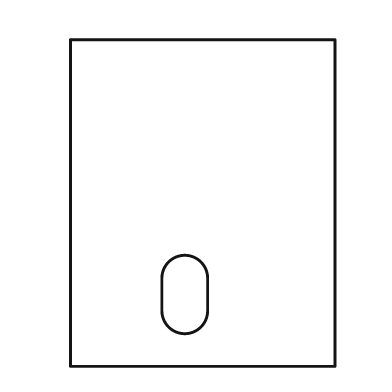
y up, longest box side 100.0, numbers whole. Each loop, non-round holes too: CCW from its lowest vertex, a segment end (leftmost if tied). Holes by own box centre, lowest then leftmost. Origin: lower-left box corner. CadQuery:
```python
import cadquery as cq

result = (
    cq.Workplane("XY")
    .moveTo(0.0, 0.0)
    .lineTo(81.0, 0.0)
    .lineTo(81.0, 100.0)
    .lineTo(0.0, 100.0)
    .close()
    .moveTo(28.0, 17.0)
    .threePointArc((35.0, 10.0), (42.0, 17.0))
    .lineTo(42.0, 27.0)
    .threePointArc((35.0, 34.0), (28.0, 27.0))
    .close()
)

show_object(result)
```